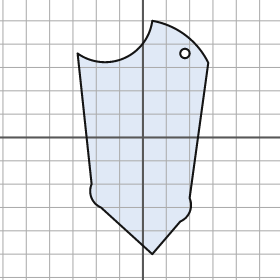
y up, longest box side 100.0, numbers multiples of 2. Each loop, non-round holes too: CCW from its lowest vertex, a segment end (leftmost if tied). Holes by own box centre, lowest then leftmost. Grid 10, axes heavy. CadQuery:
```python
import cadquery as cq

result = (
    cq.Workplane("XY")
    .moveTo(4.0, -50.0)
    .lineTo(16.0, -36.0)
    .threePointArc((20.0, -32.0), (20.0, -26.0))
    .lineTo(28.0, 32.0)
    .threePointArc((18.0, 44.0), (4.0, 50.0))
    .threePointArc((-8.0, 34.0), (-28.0, 36.0))
    .lineTo(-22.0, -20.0)
    .threePointArc((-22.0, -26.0), (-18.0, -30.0))
    .close()
    .moveTo(18.0, 36.0)
    .circle(2.0)
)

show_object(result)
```